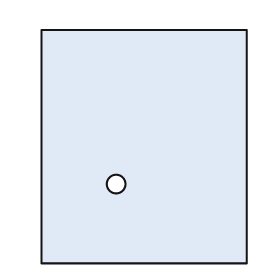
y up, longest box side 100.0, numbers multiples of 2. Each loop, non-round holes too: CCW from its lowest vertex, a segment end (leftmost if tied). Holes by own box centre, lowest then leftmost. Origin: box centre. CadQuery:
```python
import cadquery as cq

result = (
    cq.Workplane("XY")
    .moveTo(-44.0, -50.0)
    .lineTo(44.0, -50.0)
    .lineTo(44.0, 50.0)
    .lineTo(-44.0, 50.0)
    .close()
    .moveTo(-12.0, -16.0)
    .circle(4.0)
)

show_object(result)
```